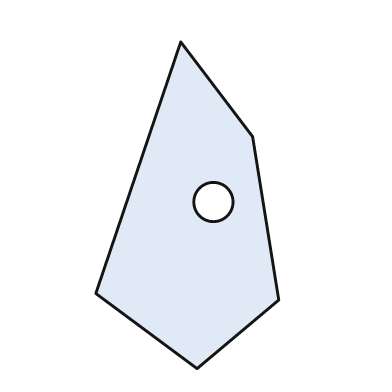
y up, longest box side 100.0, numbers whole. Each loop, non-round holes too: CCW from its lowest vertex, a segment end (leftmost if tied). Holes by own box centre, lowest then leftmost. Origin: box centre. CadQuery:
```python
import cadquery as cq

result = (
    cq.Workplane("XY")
    .moveTo(3.0, -50.0)
    .lineTo(28.0, -29.0)
    .lineTo(20.0, 21.0)
    .lineTo(-2.0, 50.0)
    .lineTo(-28.0, -27.0)
    .close()
    .moveTo(8.0, 1.0)
    .circle(6.0)
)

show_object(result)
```